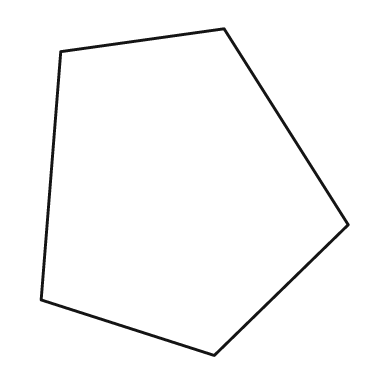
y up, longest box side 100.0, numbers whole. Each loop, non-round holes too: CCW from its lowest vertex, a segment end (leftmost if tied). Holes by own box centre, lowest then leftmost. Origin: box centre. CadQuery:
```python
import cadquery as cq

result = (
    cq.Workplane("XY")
    .moveTo(6.0, -50.0)
    .lineTo(47.0, -10.0)
    .lineTo(9.0, 50.0)
    .lineTo(-41.0, 43.0)
    .lineTo(-47.0, -33.0)
    .close()
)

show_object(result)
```